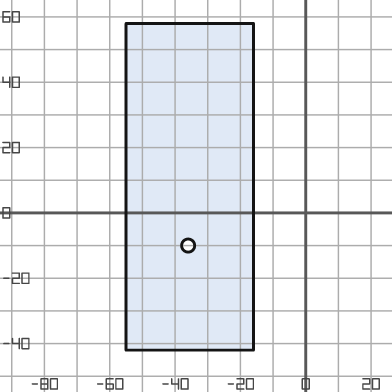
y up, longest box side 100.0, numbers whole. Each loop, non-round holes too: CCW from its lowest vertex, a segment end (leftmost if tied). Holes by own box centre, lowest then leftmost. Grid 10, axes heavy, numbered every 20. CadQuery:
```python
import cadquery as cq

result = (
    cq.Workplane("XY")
    .moveTo(-55.0, -42.0)
    .lineTo(-16.0, -42.0)
    .lineTo(-16.0, 58.0)
    .lineTo(-55.0, 58.0)
    .close()
    .moveTo(-36.0, -10.0)
    .circle(2.0)
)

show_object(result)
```